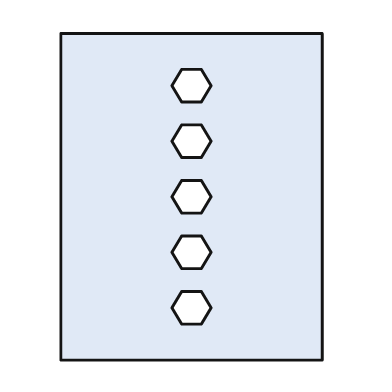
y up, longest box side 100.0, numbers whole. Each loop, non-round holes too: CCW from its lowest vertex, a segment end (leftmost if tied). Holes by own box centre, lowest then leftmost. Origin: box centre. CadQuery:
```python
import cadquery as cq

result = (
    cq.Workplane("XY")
    .moveTo(-40.0, -50.0)
    .lineTo(40.0, -50.0)
    .lineTo(40.0, 50.0)
    .lineTo(-40.0, 50.0)
    .close()
    .moveTo(-3.0, -39.0)
    .lineTo(3.0, -39.0)
    .lineTo(6.0, -34.0)
    .lineTo(3.0, -29.0)
    .lineTo(-3.0, -29.0)
    .lineTo(-6.0, -34.0)
    .close()
    .moveTo(-3.0, -22.0)
    .lineTo(3.0, -22.0)
    .lineTo(6.0, -17.0)
    .lineTo(3.0, -12.0)
    .lineTo(-3.0, -12.0)
    .lineTo(-6.0, -17.0)
    .close()
    .moveTo(-3.0, -5.0)
    .lineTo(3.0, -5.0)
    .lineTo(6.0, 0.0)
    .lineTo(3.0, 5.0)
    .lineTo(-3.0, 5.0)
    .lineTo(-6.0, 0.0)
    .close()
    .moveTo(-3.0, 12.0)
    .lineTo(3.0, 12.0)
    .lineTo(6.0, 17.0)
    .lineTo(3.0, 22.0)
    .lineTo(-3.0, 22.0)
    .lineTo(-6.0, 17.0)
    .close()
    .moveTo(-3.0, 29.0)
    .lineTo(3.0, 29.0)
    .lineTo(6.0, 34.0)
    .lineTo(3.0, 39.0)
    .lineTo(-3.0, 39.0)
    .lineTo(-6.0, 34.0)
    .close()
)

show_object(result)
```